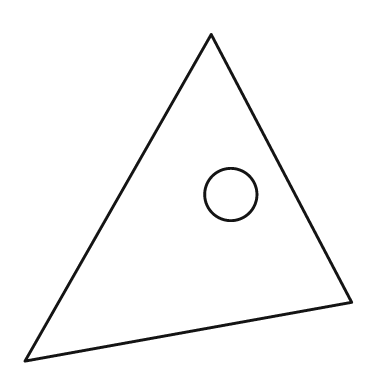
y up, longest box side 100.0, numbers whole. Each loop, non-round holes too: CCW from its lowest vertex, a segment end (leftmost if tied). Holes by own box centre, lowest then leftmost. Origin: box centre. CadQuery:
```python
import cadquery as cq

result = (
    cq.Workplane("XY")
    .moveTo(-50.0, -50.0)
    .lineTo(50.0, -32.0)
    .lineTo(7.0, 50.0)
    .close()
    .moveTo(13.0, 1.0)
    .circle(8.0)
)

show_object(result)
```